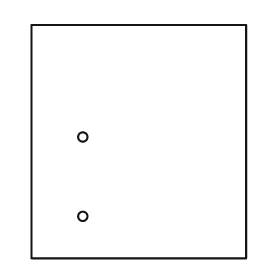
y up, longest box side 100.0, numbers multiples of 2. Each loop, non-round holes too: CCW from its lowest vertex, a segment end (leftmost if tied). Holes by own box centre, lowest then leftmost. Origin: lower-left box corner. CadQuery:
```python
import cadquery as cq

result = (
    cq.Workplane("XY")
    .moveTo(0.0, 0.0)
    .lineTo(92.0, 0.0)
    .lineTo(92.0, 100.0)
    .lineTo(0.0, 100.0)
    .close()
    .moveTo(22.0, 18.0)
    .circle(2.0)
    .moveTo(22.0, 52.0)
    .circle(2.0)
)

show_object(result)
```